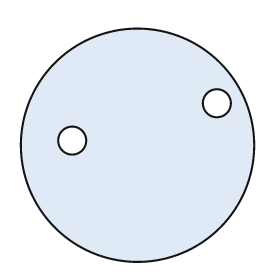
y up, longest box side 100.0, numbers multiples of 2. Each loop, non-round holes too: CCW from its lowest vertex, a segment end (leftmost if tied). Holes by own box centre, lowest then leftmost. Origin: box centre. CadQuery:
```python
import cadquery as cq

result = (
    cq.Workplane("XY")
    .moveTo(0.0, 0.0)
    .circle(50.0)
    .moveTo(-28.0, 2.0)
    .circle(6.0)
    .moveTo(34.0, 18.0)
    .circle(6.0)
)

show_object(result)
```